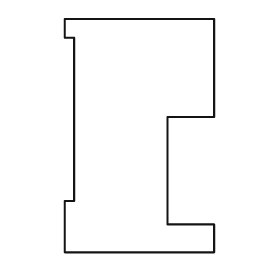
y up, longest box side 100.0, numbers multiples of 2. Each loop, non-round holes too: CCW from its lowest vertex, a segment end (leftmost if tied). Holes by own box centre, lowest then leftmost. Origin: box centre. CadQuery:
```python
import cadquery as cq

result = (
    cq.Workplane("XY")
    .moveTo(-32.0, -50.0)
    .lineTo(32.0, -50.0)
    .lineTo(32.0, -38.0)
    .lineTo(12.0, -38.0)
    .lineTo(12.0, 8.0)
    .lineTo(32.0, 8.0)
    .lineTo(32.0, 50.0)
    .lineTo(-32.0, 50.0)
    .lineTo(-32.0, 42.0)
    .lineTo(-28.0, 42.0)
    .lineTo(-28.0, -28.0)
    .lineTo(-32.0, -28.0)
    .close()
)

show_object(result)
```